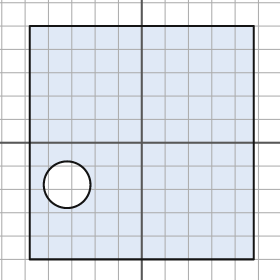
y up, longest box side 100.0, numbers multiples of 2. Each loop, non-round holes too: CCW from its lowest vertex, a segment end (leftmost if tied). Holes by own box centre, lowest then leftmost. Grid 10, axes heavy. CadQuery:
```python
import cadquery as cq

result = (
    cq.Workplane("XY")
    .moveTo(-48.0, -50.0)
    .lineTo(48.0, -50.0)
    .lineTo(48.0, 50.0)
    .lineTo(-48.0, 50.0)
    .close()
    .moveTo(-32.0, -18.0)
    .circle(10.0)
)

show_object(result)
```